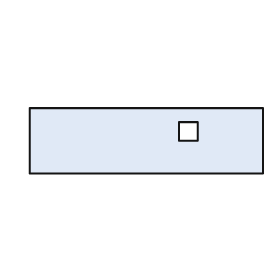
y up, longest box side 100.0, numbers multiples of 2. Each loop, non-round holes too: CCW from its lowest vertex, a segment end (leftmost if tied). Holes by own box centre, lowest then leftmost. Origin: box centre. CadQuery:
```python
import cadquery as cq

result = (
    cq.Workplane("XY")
    .moveTo(-50.0, -14.0)
    .lineTo(50.0, -14.0)
    .lineTo(50.0, 14.0)
    .lineTo(-50.0, 14.0)
    .close()
    .moveTo(14.0, 0.0)
    .lineTo(22.0, 0.0)
    .lineTo(22.0, 8.0)
    .lineTo(14.0, 8.0)
    .close()
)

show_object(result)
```